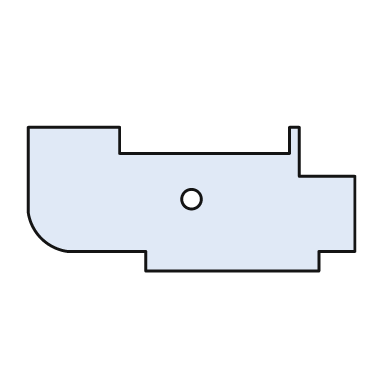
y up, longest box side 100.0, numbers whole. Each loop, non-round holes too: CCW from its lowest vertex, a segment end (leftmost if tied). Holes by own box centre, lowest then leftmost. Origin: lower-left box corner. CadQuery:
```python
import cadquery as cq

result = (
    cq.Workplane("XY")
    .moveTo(36.0, 0.0)
    .lineTo(89.0, 0.0)
    .lineTo(89.0, 6.0)
    .lineTo(100.0, 6.0)
    .lineTo(100.0, 29.0)
    .lineTo(83.0, 29.0)
    .lineTo(83.0, 44.0)
    .lineTo(80.0, 44.0)
    .lineTo(80.0, 36.0)
    .lineTo(28.0, 36.0)
    .lineTo(28.0, 44.0)
    .lineTo(0.0, 44.0)
    .lineTo(0.0, 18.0)
    .threePointArc((4.0, 10.0), (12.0, 6.0))
    .lineTo(36.0, 6.0)
    .close()
    .moveTo(50.0, 22.0)
    .circle(3.0)
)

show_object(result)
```